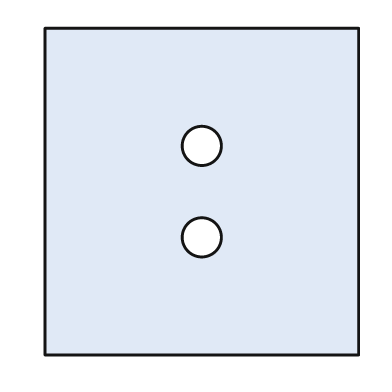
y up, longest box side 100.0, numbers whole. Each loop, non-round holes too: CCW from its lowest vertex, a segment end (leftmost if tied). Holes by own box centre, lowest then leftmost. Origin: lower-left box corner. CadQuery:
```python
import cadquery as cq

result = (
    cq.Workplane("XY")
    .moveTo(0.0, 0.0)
    .lineTo(96.0, 0.0)
    .lineTo(96.0, 100.0)
    .lineTo(0.0, 100.0)
    .close()
    .moveTo(48.0, 36.0)
    .circle(6.0)
    .moveTo(48.0, 64.0)
    .circle(6.0)
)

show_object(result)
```